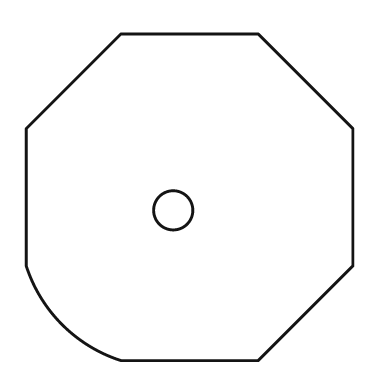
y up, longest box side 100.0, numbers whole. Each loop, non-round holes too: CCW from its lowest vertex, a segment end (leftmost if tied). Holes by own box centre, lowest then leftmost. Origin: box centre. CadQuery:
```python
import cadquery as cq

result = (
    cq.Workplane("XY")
    .moveTo(-21.0, -50.0)
    .lineTo(21.0, -50.0)
    .lineTo(50.0, -21.0)
    .lineTo(50.0, 21.0)
    .lineTo(21.0, 50.0)
    .lineTo(-21.0, 50.0)
    .lineTo(-50.0, 21.0)
    .lineTo(-50.0, -21.0)
    .threePointArc((-39.0, -39.0), (-21.0, -50.0))
    .close()
    .moveTo(-5.0, -4.0)
    .circle(6.0)
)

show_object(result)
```